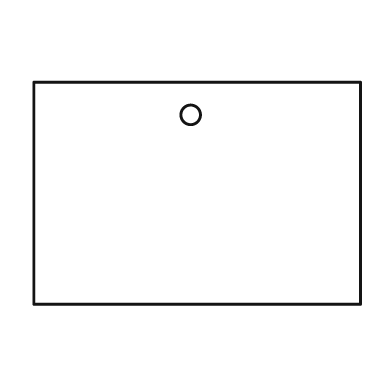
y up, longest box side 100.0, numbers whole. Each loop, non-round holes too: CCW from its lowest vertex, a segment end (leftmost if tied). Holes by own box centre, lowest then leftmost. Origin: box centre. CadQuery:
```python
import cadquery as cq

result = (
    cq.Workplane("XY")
    .moveTo(-50.0, -34.0)
    .lineTo(50.0, -34.0)
    .lineTo(50.0, 34.0)
    .lineTo(-50.0, 34.0)
    .close()
    .moveTo(-2.0, 24.0)
    .circle(3.0)
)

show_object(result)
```